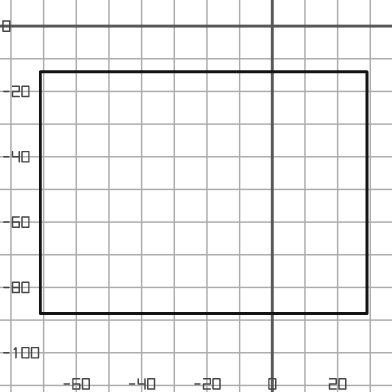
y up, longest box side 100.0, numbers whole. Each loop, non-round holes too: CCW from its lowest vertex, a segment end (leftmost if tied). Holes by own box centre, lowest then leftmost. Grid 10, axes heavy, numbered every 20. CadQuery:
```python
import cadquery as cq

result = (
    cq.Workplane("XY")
    .moveTo(-71.0, -88.0)
    .lineTo(29.0, -88.0)
    .lineTo(29.0, -14.0)
    .lineTo(-71.0, -14.0)
    .close()
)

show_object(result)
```